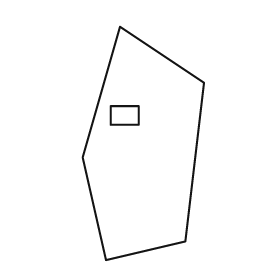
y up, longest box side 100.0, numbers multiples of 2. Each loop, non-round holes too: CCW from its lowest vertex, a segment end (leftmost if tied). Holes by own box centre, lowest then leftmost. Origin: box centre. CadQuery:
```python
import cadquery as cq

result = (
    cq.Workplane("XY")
    .moveTo(-16.0, -50.0)
    .lineTo(18.0, -42.0)
    .lineTo(26.0, 26.0)
    .lineTo(-10.0, 50.0)
    .lineTo(-26.0, -6.0)
    .close()
    .moveTo(-14.0, 8.0)
    .lineTo(-2.0, 8.0)
    .lineTo(-2.0, 16.0)
    .lineTo(-14.0, 16.0)
    .close()
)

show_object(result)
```